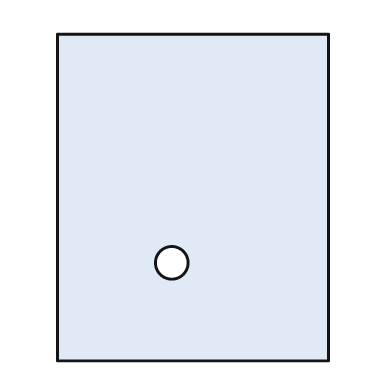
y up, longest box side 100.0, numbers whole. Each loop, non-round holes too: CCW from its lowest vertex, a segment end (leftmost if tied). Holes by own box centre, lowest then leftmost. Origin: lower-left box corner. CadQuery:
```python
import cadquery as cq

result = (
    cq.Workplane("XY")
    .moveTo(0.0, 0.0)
    .lineTo(83.0, 0.0)
    .lineTo(83.0, 100.0)
    .lineTo(0.0, 100.0)
    .close()
    .moveTo(35.0, 30.0)
    .circle(5.0)
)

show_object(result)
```